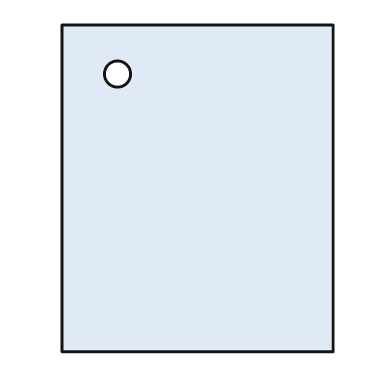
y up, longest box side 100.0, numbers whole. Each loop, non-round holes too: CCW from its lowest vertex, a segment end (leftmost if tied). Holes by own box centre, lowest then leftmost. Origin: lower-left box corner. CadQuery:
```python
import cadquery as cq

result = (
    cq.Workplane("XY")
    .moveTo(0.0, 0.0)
    .lineTo(83.0, 0.0)
    .lineTo(83.0, 100.0)
    .lineTo(0.0, 100.0)
    .close()
    .moveTo(17.0, 85.0)
    .circle(4.0)
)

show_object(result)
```